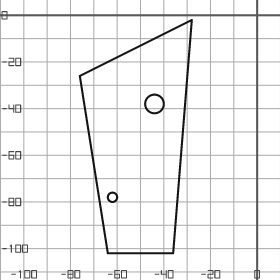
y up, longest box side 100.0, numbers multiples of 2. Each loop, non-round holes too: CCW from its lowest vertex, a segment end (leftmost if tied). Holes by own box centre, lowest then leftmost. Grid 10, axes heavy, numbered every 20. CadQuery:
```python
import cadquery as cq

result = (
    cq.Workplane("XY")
    .moveTo(-64.0, -102.0)
    .lineTo(-36.0, -102.0)
    .lineTo(-28.0, -2.0)
    .lineTo(-76.0, -26.0)
    .close()
    .moveTo(-62.0, -78.0)
    .circle(2.0)
    .moveTo(-44.0, -38.0)
    .circle(4.0)
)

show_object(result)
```